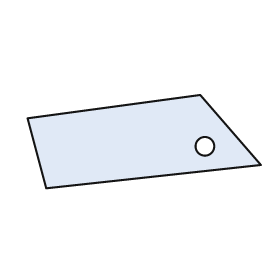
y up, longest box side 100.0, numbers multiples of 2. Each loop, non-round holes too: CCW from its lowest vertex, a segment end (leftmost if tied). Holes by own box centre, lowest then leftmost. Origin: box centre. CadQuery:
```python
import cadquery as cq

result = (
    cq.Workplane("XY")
    .moveTo(-42.0, -20.0)
    .lineTo(50.0, -10.0)
    .lineTo(24.0, 20.0)
    .lineTo(-50.0, 10.0)
    .close()
    .moveTo(26.0, -2.0)
    .circle(4.0)
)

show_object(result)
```